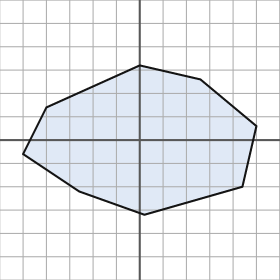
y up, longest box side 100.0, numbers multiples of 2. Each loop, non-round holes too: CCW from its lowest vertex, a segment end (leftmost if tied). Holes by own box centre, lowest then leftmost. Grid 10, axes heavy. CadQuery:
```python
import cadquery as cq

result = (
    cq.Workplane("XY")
    .moveTo(2.0, -32.0)
    .lineTo(44.0, -20.0)
    .lineTo(50.0, 6.0)
    .lineTo(26.0, 26.0)
    .lineTo(0.0, 32.0)
    .lineTo(-40.0, 14.0)
    .lineTo(-50.0, -6.0)
    .lineTo(-26.0, -22.0)
    .close()
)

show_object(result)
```